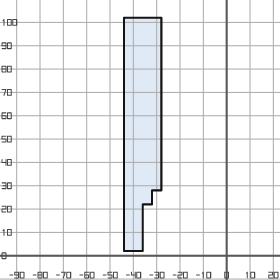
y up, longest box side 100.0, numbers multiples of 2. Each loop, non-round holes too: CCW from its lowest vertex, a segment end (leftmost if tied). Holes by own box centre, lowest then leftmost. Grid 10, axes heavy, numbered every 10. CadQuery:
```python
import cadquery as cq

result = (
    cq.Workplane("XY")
    .moveTo(-44.0, 2.0)
    .lineTo(-36.0, 2.0)
    .lineTo(-36.0, 22.0)
    .lineTo(-32.0, 22.0)
    .lineTo(-32.0, 28.0)
    .lineTo(-28.0, 28.0)
    .lineTo(-28.0, 102.0)
    .lineTo(-44.0, 102.0)
    .close()
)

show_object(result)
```